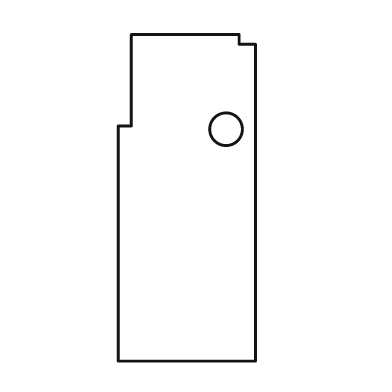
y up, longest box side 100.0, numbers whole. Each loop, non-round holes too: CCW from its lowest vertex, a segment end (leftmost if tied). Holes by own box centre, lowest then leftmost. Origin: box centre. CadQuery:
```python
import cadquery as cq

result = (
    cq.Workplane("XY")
    .moveTo(-21.0, -50.0)
    .lineTo(21.0, -50.0)
    .lineTo(21.0, 47.0)
    .lineTo(16.0, 47.0)
    .lineTo(16.0, 50.0)
    .lineTo(-17.0, 50.0)
    .lineTo(-17.0, 22.0)
    .lineTo(-21.0, 22.0)
    .close()
    .moveTo(12.0, 21.0)
    .circle(5.0)
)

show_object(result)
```